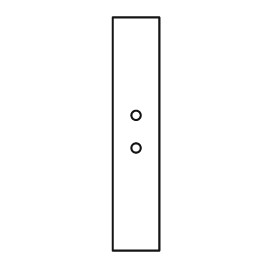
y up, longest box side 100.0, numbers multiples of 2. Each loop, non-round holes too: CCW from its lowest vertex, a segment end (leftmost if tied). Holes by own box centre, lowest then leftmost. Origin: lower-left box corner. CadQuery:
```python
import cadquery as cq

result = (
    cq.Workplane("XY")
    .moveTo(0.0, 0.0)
    .lineTo(20.0, 0.0)
    .lineTo(20.0, 100.0)
    .lineTo(0.0, 100.0)
    .close()
    .moveTo(10.0, 44.0)
    .circle(2.0)
    .moveTo(10.0, 58.0)
    .circle(2.0)
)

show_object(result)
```